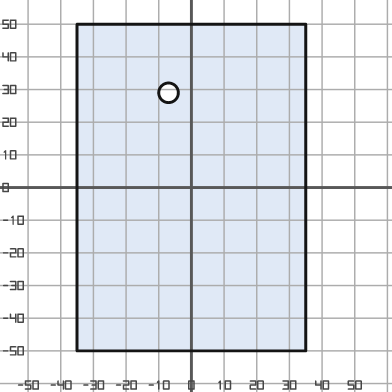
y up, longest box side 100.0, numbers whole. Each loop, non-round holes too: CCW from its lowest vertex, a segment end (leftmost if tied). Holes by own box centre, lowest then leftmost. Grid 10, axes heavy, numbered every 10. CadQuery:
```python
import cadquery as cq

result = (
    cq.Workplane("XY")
    .moveTo(-35.0, -50.0)
    .lineTo(35.0, -50.0)
    .lineTo(35.0, 50.0)
    .lineTo(-35.0, 50.0)
    .close()
    .moveTo(-7.0, 29.0)
    .circle(3.0)
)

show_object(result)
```